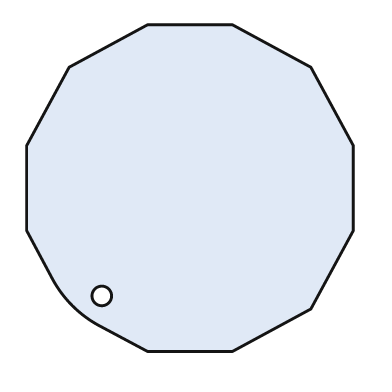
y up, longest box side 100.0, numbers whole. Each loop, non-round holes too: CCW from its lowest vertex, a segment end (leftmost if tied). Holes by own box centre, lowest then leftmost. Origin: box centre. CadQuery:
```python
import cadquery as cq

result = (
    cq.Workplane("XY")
    .moveTo(-13.0, -50.0)
    .lineTo(13.0, -50.0)
    .lineTo(37.0, -37.0)
    .lineTo(50.0, -13.0)
    .lineTo(50.0, 13.0)
    .lineTo(37.0, 37.0)
    .lineTo(13.0, 50.0)
    .lineTo(-13.0, 50.0)
    .lineTo(-37.0, 37.0)
    .lineTo(-50.0, 13.0)
    .lineTo(-50.0, -13.0)
    .lineTo(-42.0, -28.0)
    .threePointArc((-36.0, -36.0), (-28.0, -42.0))
    .close()
    .moveTo(-27.0, -33.0)
    .circle(3.0)
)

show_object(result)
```